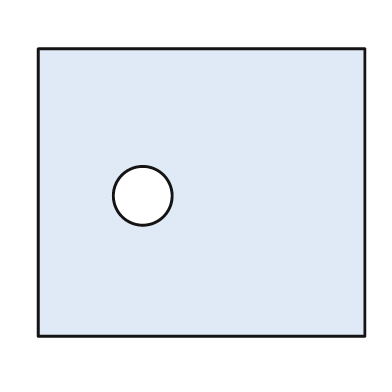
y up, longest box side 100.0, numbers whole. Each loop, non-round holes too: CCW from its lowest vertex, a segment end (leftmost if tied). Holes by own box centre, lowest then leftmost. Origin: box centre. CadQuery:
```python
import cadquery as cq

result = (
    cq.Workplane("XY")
    .moveTo(-50.0, -44.0)
    .lineTo(50.0, -44.0)
    .lineTo(50.0, 44.0)
    .lineTo(-50.0, 44.0)
    .close()
    .moveTo(-18.0, -1.0)
    .circle(9.0)
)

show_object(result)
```